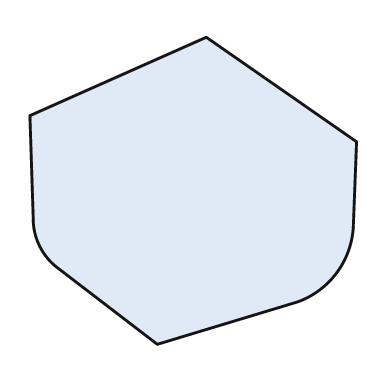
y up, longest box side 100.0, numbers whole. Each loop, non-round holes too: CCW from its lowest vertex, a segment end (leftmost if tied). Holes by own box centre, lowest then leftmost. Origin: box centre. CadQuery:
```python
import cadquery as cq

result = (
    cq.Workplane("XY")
    .moveTo(-11.0, -47.0)
    .lineTo(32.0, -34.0)
    .threePointArc((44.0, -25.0), (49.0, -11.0))
    .lineTo(50.0, 15.0)
    .lineTo(4.0, 47.0)
    .lineTo(-50.0, 23.0)
    .lineTo(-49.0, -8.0)
    .threePointArc((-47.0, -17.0), (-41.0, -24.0))
    .close()
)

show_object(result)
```